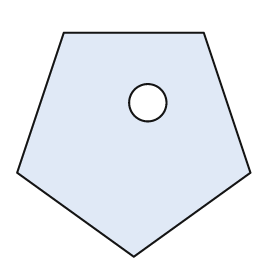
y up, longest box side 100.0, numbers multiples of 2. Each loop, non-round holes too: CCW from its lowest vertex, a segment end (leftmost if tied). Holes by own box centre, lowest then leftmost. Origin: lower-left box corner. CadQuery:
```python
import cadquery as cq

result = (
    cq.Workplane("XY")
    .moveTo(50.0, 0.0)
    .lineTo(100.0, 36.0)
    .lineTo(80.0, 96.0)
    .lineTo(20.0, 96.0)
    .lineTo(0.0, 36.0)
    .close()
    .moveTo(56.0, 66.0)
    .circle(8.0)
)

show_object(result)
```